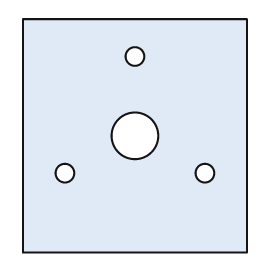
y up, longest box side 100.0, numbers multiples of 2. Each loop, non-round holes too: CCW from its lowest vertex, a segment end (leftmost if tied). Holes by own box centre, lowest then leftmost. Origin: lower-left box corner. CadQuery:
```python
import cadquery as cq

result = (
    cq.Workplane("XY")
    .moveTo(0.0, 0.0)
    .lineTo(96.0, 0.0)
    .lineTo(96.0, 100.0)
    .lineTo(0.0, 100.0)
    .close()
    .moveTo(18.0, 34.0)
    .circle(4.0)
    .moveTo(78.0, 34.0)
    .circle(4.0)
    .moveTo(48.0, 50.0)
    .circle(10.0)
    .moveTo(48.0, 84.0)
    .circle(4.0)
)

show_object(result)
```